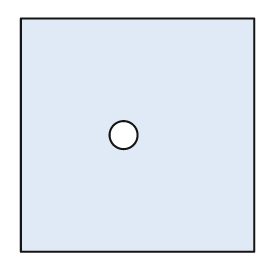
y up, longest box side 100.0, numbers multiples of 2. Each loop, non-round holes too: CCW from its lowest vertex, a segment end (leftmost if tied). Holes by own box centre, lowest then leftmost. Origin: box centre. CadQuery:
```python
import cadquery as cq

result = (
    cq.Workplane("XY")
    .moveTo(-50.0, -50.0)
    .lineTo(50.0, -50.0)
    .lineTo(50.0, 50.0)
    .lineTo(-50.0, 50.0)
    .close()
    .moveTo(-6.0, 0.0)
    .circle(6.0)
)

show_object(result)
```